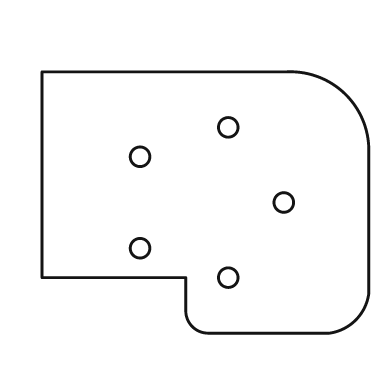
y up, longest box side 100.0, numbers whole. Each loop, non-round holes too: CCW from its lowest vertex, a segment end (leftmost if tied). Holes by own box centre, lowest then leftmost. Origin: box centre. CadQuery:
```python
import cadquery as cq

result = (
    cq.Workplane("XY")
    .moveTo(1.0, -40.0)
    .lineTo(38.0, -40.0)
    .threePointArc((46.0, -36.0), (50.0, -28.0))
    .lineTo(50.0, 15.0)
    .threePointArc((43.0, 33.0), (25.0, 40.0))
    .lineTo(-50.0, 40.0)
    .lineTo(-50.0, -23.0)
    .lineTo(-6.0, -23.0)
    .lineTo(-6.0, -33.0)
    .threePointArc((-4.0, -38.0), (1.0, -40.0))
    .close()
    .moveTo(7.0, -23.0)
    .circle(3.0)
    .moveTo(-20.0, -14.0)
    .circle(3.0)
    .moveTo(24.0, 0.0)
    .circle(3.0)
    .moveTo(-20.0, 14.0)
    .circle(3.0)
    .moveTo(7.0, 23.0)
    .circle(3.0)
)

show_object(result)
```